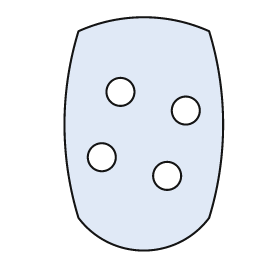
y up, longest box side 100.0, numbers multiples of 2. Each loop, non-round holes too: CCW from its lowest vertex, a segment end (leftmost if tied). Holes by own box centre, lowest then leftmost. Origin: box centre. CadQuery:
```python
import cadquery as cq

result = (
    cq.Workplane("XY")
    .moveTo(-28.0, -36.0)
    .threePointArc((0.0, -50.0), (28.0, -36.0))
    .threePointArc((34.0, 4.0), (28.0, 44.0))
    .threePointArc((0.0, 50.0), (-28.0, 44.0))
    .threePointArc((-34.0, 4.0), (-28.0, -36.0))
    .close()
    .moveTo(10.0, -18.0)
    .circle(6.0)
    .moveTo(-18.0, -10.0)
    .circle(6.0)
    .moveTo(18.0, 10.0)
    .circle(6.0)
    .moveTo(-10.0, 18.0)
    .circle(6.0)
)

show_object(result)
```